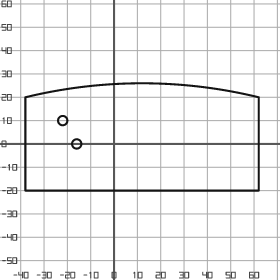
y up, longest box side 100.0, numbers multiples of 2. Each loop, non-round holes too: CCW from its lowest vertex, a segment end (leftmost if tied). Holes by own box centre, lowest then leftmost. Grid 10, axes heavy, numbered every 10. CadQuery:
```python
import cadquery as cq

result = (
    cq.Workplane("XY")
    .moveTo(-38.0, -20.0)
    .lineTo(62.0, -20.0)
    .lineTo(62.0, 20.0)
    .threePointArc((12.0, 26.0), (-38.0, 20.0))
    .close()
    .moveTo(-16.0, 0.0)
    .circle(2.0)
    .moveTo(-22.0, 10.0)
    .circle(2.0)
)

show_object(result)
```